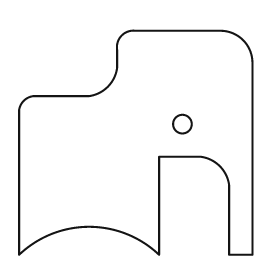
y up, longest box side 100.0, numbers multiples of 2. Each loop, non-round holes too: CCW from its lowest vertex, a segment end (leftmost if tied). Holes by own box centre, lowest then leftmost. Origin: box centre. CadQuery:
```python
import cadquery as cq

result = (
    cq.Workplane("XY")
    .moveTo(-50.0, -48.0)
    .threePointArc((-20.0, -36.0), (10.0, -48.0))
    .lineTo(10.0, -6.0)
    .lineTo(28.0, -6.0)
    .threePointArc((36.0, -10.0), (40.0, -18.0))
    .lineTo(40.0, -48.0)
    .lineTo(50.0, -48.0)
    .lineTo(50.0, 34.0)
    .threePointArc((46.0, 44.0), (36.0, 48.0))
    .lineTo(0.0, 48.0)
    .threePointArc((-6.0, 46.0), (-8.0, 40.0))
    .lineTo(-8.0, 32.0)
    .threePointArc((-12.0, 24.0), (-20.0, 20.0))
    .lineTo(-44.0, 20.0)
    .threePointArc((-48.0, 18.0), (-50.0, 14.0))
    .close()
    .moveTo(20.0, 8.0)
    .circle(4.0)
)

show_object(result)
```